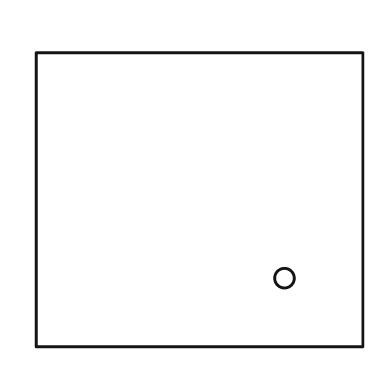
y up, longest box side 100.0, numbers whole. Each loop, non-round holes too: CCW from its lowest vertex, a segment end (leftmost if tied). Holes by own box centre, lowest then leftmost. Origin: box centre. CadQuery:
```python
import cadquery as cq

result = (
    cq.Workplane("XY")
    .moveTo(-50.0, -45.0)
    .lineTo(50.0, -45.0)
    .lineTo(50.0, 45.0)
    .lineTo(-50.0, 45.0)
    .close()
    .moveTo(26.0, -24.0)
    .circle(3.0)
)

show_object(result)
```